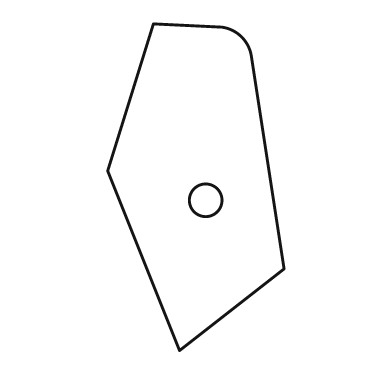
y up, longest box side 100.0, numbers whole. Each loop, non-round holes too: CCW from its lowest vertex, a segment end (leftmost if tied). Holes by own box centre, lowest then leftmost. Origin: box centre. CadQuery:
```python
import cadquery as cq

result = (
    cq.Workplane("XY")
    .moveTo(-5.0, -50.0)
    .lineTo(27.0, -25.0)
    .lineTo(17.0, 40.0)
    .threePointArc((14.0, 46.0), (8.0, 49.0))
    .lineTo(-13.0, 50.0)
    .lineTo(-27.0, 5.0)
    .close()
    .moveTo(3.0, -4.0)
    .circle(5.0)
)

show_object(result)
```